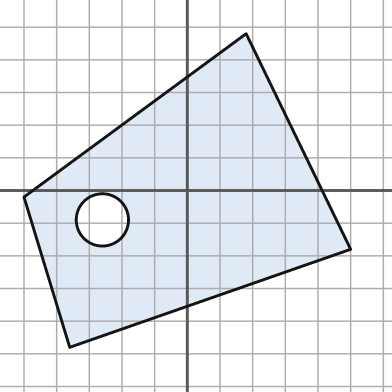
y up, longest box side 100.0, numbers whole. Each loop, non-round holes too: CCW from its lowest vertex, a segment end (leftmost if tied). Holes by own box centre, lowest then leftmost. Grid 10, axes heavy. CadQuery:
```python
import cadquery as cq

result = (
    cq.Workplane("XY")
    .moveTo(-36.0, -48.0)
    .lineTo(50.0, -18.0)
    .lineTo(18.0, 48.0)
    .lineTo(-50.0, -2.0)
    .close()
    .moveTo(-26.0, -9.0)
    .circle(8.0)
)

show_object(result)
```